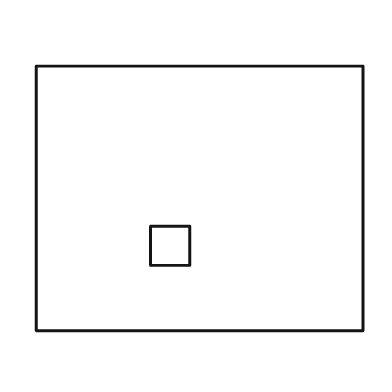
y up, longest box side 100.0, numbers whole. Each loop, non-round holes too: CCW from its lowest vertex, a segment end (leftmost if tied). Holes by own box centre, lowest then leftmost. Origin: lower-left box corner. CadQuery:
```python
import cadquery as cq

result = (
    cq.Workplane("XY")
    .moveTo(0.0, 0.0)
    .lineTo(100.0, 0.0)
    .lineTo(100.0, 81.0)
    .lineTo(0.0, 81.0)
    .close()
    .moveTo(35.0, 20.0)
    .lineTo(47.0, 20.0)
    .lineTo(47.0, 32.0)
    .lineTo(35.0, 32.0)
    .close()
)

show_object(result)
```